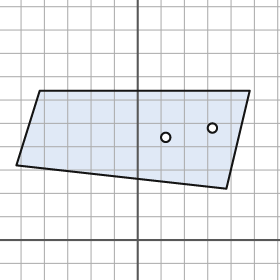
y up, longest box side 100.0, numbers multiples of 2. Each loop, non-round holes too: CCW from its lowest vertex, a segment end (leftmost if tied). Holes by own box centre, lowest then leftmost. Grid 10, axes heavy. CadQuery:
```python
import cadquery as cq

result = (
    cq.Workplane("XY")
    .moveTo(38.0, 22.0)
    .lineTo(48.0, 64.0)
    .lineTo(-42.0, 64.0)
    .lineTo(-52.0, 32.0)
    .close()
    .moveTo(12.0, 44.0)
    .circle(2.0)
    .moveTo(32.0, 48.0)
    .circle(2.0)
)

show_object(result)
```